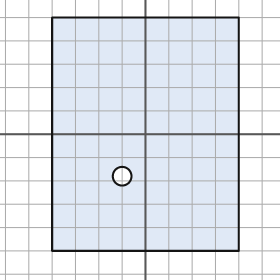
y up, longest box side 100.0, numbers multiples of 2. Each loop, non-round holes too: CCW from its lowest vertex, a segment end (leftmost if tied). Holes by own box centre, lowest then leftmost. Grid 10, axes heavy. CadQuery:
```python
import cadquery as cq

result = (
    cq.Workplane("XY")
    .moveTo(-40.0, -50.0)
    .lineTo(40.0, -50.0)
    .lineTo(40.0, 50.0)
    .lineTo(-40.0, 50.0)
    .close()
    .moveTo(-10.0, -18.0)
    .circle(4.0)
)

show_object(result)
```